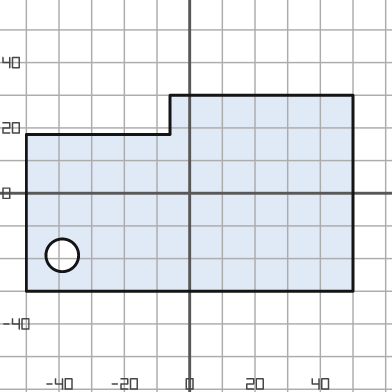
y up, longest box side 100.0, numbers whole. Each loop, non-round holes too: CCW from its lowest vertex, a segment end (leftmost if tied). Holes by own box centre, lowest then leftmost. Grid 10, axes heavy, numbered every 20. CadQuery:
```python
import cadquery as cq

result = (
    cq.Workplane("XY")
    .moveTo(-50.0, -30.0)
    .lineTo(50.0, -30.0)
    .lineTo(50.0, 30.0)
    .lineTo(-6.0, 30.0)
    .lineTo(-6.0, 18.0)
    .lineTo(-50.0, 18.0)
    .close()
    .moveTo(-39.0, -19.0)
    .circle(5.0)
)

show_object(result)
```